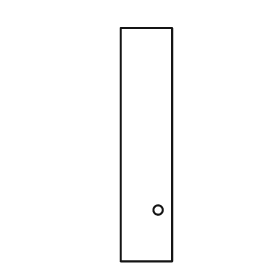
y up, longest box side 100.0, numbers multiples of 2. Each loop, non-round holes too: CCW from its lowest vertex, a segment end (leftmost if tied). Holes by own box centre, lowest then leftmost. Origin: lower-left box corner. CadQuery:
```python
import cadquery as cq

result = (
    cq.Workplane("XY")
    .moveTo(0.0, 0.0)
    .lineTo(22.0, 0.0)
    .lineTo(22.0, 100.0)
    .lineTo(0.0, 100.0)
    .close()
    .moveTo(16.0, 22.0)
    .circle(2.0)
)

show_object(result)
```